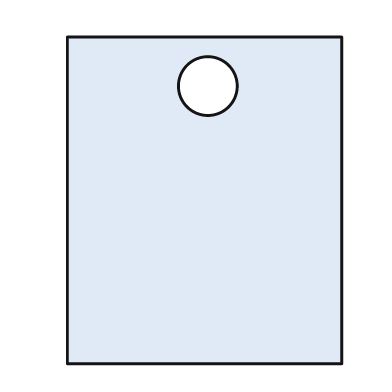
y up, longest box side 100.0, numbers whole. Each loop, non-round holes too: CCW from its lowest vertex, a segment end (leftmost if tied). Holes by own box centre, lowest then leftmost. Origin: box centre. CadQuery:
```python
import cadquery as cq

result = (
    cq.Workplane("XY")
    .moveTo(-42.0, -50.0)
    .lineTo(42.0, -50.0)
    .lineTo(42.0, 50.0)
    .lineTo(-42.0, 50.0)
    .close()
    .moveTo(1.0, 35.0)
    .circle(9.0)
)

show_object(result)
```